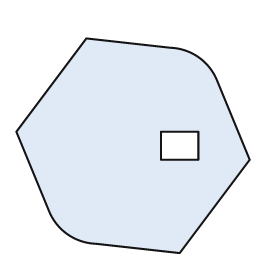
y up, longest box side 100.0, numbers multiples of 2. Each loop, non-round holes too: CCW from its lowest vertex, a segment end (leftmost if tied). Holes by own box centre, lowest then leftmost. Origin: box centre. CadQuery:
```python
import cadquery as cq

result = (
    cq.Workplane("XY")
    .moveTo(20.0, -46.0)
    .lineTo(50.0, -6.0)
    .lineTo(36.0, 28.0)
    .threePointArc((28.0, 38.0), (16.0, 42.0))
    .lineTo(-20.0, 46.0)
    .lineTo(-50.0, 6.0)
    .lineTo(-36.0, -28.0)
    .threePointArc((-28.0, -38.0), (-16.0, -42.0))
    .close()
    .moveTo(12.0, -6.0)
    .lineTo(28.0, -6.0)
    .lineTo(28.0, 6.0)
    .lineTo(12.0, 6.0)
    .close()
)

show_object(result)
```